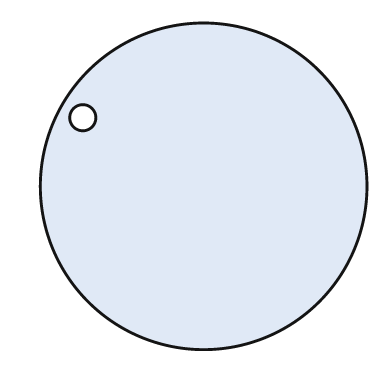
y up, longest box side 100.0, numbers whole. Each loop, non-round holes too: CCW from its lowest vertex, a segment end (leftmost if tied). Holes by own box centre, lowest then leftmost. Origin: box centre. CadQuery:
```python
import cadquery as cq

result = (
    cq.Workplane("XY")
    .moveTo(0.0, 0.0)
    .circle(50.0)
    .moveTo(-37.0, 21.0)
    .circle(4.0)
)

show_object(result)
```